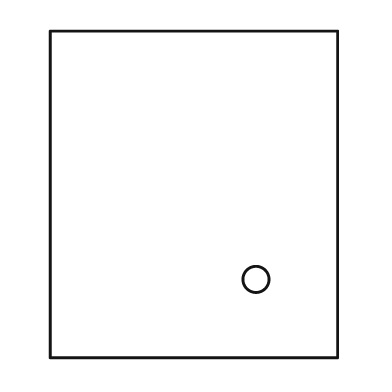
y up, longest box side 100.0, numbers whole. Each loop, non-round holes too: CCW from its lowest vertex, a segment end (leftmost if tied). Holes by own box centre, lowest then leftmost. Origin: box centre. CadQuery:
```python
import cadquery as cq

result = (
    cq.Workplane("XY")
    .moveTo(-44.0, -50.0)
    .lineTo(44.0, -50.0)
    .lineTo(44.0, 50.0)
    .lineTo(-44.0, 50.0)
    .close()
    .moveTo(19.0, -26.0)
    .circle(4.0)
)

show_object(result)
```